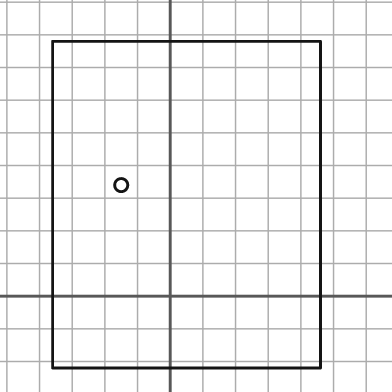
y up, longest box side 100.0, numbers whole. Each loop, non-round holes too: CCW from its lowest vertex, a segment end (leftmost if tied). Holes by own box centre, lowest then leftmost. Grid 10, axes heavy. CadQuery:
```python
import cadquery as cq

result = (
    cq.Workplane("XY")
    .moveTo(-36.0, -22.0)
    .lineTo(46.0, -22.0)
    .lineTo(46.0, 78.0)
    .lineTo(-36.0, 78.0)
    .close()
    .moveTo(-15.0, 34.0)
    .circle(2.0)
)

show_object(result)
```